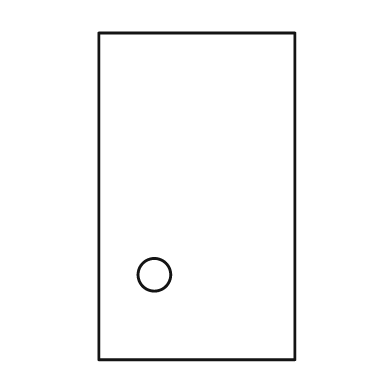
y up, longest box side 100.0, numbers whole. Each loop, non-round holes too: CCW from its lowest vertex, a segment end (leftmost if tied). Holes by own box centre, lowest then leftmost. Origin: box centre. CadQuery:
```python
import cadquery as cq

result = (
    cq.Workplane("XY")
    .moveTo(-30.0, -50.0)
    .lineTo(30.0, -50.0)
    .lineTo(30.0, 50.0)
    .lineTo(-30.0, 50.0)
    .close()
    .moveTo(-13.0, -24.0)
    .circle(5.0)
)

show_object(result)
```